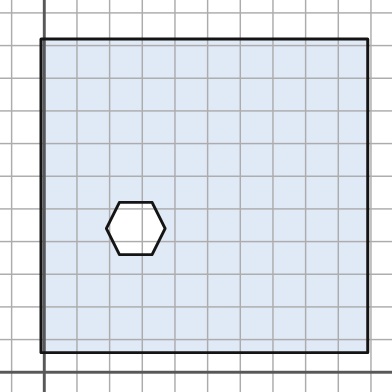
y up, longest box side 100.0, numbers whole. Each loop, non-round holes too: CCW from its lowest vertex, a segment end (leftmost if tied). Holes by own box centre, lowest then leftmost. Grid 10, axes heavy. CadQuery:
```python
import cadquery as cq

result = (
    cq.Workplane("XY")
    .moveTo(-1.0, 6.0)
    .lineTo(99.0, 6.0)
    .lineTo(99.0, 102.0)
    .lineTo(-1.0, 102.0)
    .close()
    .moveTo(23.0, 36.0)
    .lineTo(33.0, 36.0)
    .lineTo(37.0, 44.0)
    .lineTo(33.0, 52.0)
    .lineTo(23.0, 52.0)
    .lineTo(19.0, 44.0)
    .close()
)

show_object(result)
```